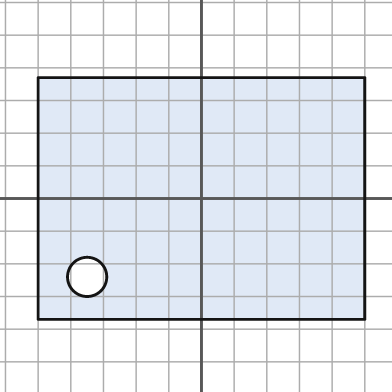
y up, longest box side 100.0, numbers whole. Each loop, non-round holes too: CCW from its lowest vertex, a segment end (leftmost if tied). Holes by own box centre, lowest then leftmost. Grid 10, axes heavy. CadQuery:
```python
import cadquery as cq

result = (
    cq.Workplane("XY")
    .moveTo(-50.0, -37.0)
    .lineTo(50.0, -37.0)
    .lineTo(50.0, 37.0)
    .lineTo(-50.0, 37.0)
    .close()
    .moveTo(-35.0, -24.0)
    .circle(6.0)
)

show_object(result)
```